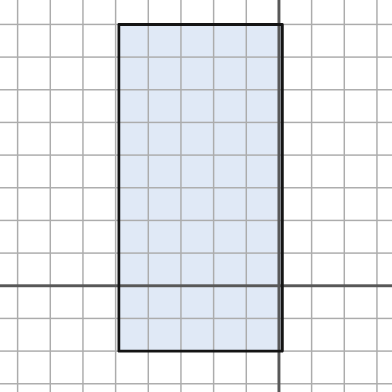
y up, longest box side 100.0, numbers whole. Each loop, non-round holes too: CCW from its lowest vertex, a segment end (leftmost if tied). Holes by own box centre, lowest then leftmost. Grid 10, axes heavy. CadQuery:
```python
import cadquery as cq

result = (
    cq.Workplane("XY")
    .moveTo(-49.0, -20.0)
    .lineTo(1.0, -20.0)
    .lineTo(1.0, 80.0)
    .lineTo(-49.0, 80.0)
    .close()
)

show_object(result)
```